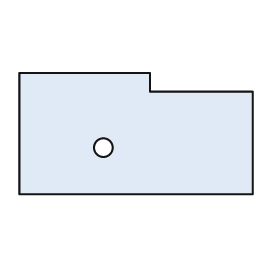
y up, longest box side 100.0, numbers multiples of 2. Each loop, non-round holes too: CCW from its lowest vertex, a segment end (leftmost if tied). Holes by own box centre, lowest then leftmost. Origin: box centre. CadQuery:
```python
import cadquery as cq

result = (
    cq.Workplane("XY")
    .moveTo(-50.0, -26.0)
    .lineTo(50.0, -26.0)
    .lineTo(50.0, 18.0)
    .lineTo(6.0, 18.0)
    .lineTo(6.0, 26.0)
    .lineTo(-50.0, 26.0)
    .close()
    .moveTo(-14.0, -6.0)
    .circle(4.0)
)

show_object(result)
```